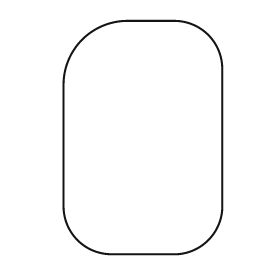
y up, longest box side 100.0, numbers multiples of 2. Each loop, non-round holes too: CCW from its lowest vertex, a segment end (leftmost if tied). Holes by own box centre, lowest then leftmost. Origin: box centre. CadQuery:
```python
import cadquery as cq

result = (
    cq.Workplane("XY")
    .moveTo(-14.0, -50.0)
    .lineTo(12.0, -50.0)
    .threePointArc((28.0, -44.0), (34.0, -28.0))
    .lineTo(34.0, 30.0)
    .threePointArc((28.0, 44.0), (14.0, 50.0))
    .lineTo(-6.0, 50.0)
    .threePointArc((-26.0, 42.0), (-34.0, 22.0))
    .lineTo(-34.0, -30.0)
    .threePointArc((-28.0, -44.0), (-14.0, -50.0))
    .close()
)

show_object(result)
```